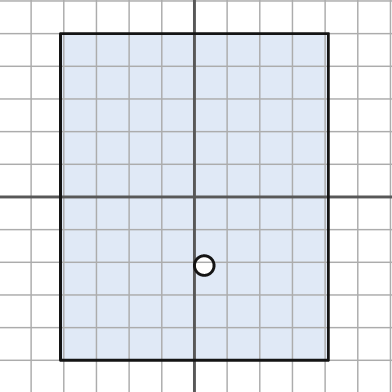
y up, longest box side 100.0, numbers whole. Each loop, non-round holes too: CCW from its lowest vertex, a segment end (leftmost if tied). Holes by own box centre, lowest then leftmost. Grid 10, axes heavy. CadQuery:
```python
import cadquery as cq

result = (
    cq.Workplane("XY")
    .moveTo(-41.0, -50.0)
    .lineTo(41.0, -50.0)
    .lineTo(41.0, 50.0)
    .lineTo(-41.0, 50.0)
    .close()
    .moveTo(3.0, -21.0)
    .circle(3.0)
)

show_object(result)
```